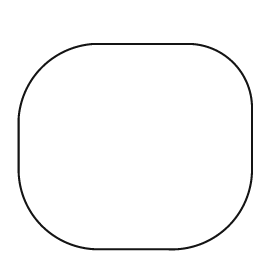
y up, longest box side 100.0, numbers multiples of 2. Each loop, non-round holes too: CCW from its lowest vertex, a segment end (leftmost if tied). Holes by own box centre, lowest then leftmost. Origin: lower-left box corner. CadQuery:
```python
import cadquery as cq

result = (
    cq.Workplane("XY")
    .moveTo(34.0, 0.0)
    .lineTo(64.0, 0.0)
    .threePointArc((90.0, 10.0), (100.0, 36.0))
    .lineTo(100.0, 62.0)
    .threePointArc((92.0, 80.0), (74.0, 88.0))
    .lineTo(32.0, 88.0)
    .threePointArc((10.0, 78.0), (0.0, 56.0))
    .lineTo(0.0, 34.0)
    .threePointArc((10.0, 10.0), (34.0, 0.0))
    .close()
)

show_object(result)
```